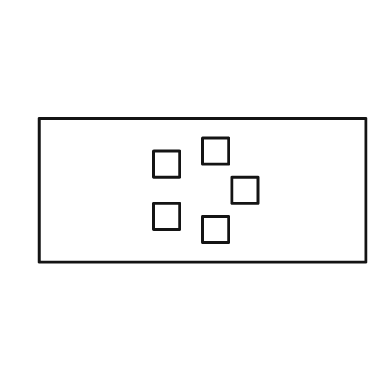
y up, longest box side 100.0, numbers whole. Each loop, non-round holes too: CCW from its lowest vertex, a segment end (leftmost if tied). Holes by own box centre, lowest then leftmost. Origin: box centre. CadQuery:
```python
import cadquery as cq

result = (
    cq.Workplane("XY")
    .moveTo(-50.0, -22.0)
    .lineTo(50.0, -22.0)
    .lineTo(50.0, 22.0)
    .lineTo(-50.0, 22.0)
    .close()
    .moveTo(0.0, -16.0)
    .lineTo(8.0, -16.0)
    .lineTo(8.0, -8.0)
    .lineTo(0.0, -8.0)
    .close()
    .moveTo(-15.0, -12.0)
    .lineTo(-7.0, -12.0)
    .lineTo(-7.0, -4.0)
    .lineTo(-15.0, -4.0)
    .close()
    .moveTo(9.0, -4.0)
    .lineTo(17.0, -4.0)
    .lineTo(17.0, 4.0)
    .lineTo(9.0, 4.0)
    .close()
    .moveTo(-15.0, 4.0)
    .lineTo(-7.0, 4.0)
    .lineTo(-7.0, 12.0)
    .lineTo(-15.0, 12.0)
    .close()
    .moveTo(0.0, 8.0)
    .lineTo(8.0, 8.0)
    .lineTo(8.0, 16.0)
    .lineTo(0.0, 16.0)
    .close()
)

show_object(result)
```